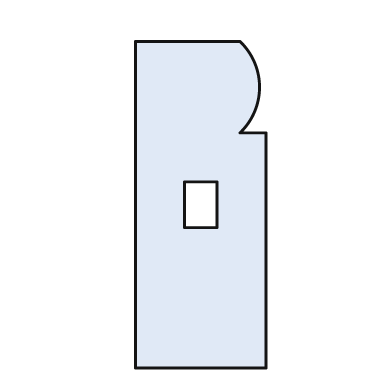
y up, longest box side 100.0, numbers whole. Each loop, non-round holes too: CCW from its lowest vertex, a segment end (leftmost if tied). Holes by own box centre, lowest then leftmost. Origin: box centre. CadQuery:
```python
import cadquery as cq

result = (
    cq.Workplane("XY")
    .moveTo(-20.0, -50.0)
    .lineTo(20.0, -50.0)
    .lineTo(20.0, 22.0)
    .lineTo(12.0, 22.0)
    .threePointArc((18.0, 36.0), (12.0, 50.0))
    .lineTo(-20.0, 50.0)
    .close()
    .moveTo(-5.0, -7.0)
    .lineTo(5.0, -7.0)
    .lineTo(5.0, 7.0)
    .lineTo(-5.0, 7.0)
    .close()
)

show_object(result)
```